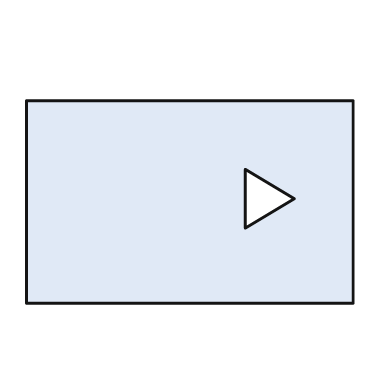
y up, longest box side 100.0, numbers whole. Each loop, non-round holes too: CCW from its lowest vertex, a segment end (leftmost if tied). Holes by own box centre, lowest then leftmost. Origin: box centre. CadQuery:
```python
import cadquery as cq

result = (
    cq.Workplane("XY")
    .moveTo(-50.0, -31.0)
    .lineTo(50.0, -31.0)
    .lineTo(50.0, 31.0)
    .lineTo(-50.0, 31.0)
    .close()
    .moveTo(17.0, -8.0)
    .lineTo(32.0, 1.0)
    .lineTo(17.0, 10.0)
    .close()
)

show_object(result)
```